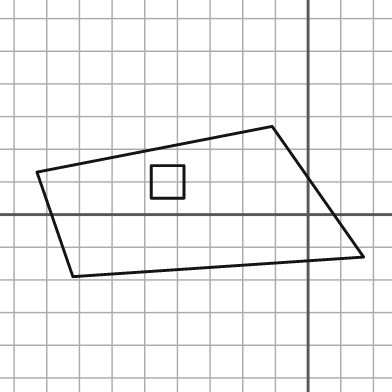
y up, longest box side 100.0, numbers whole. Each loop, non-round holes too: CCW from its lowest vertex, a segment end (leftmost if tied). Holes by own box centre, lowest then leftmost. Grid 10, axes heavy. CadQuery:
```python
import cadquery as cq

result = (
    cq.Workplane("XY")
    .moveTo(-72.0, -19.0)
    .lineTo(17.0, -13.0)
    .lineTo(-11.0, 27.0)
    .lineTo(-83.0, 13.0)
    .close()
    .moveTo(-48.0, 5.0)
    .lineTo(-38.0, 5.0)
    .lineTo(-38.0, 15.0)
    .lineTo(-48.0, 15.0)
    .close()
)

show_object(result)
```